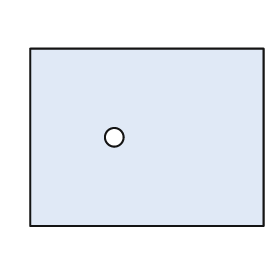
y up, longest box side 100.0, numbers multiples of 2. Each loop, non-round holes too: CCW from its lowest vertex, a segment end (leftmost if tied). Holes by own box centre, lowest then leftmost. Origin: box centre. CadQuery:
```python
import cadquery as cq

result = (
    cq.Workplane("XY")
    .moveTo(-50.0, -38.0)
    .lineTo(50.0, -38.0)
    .lineTo(50.0, 38.0)
    .lineTo(-50.0, 38.0)
    .close()
    .moveTo(-14.0, 0.0)
    .circle(4.0)
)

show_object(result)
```